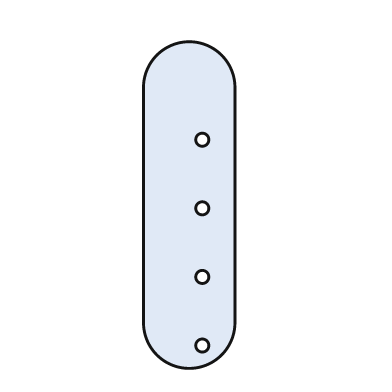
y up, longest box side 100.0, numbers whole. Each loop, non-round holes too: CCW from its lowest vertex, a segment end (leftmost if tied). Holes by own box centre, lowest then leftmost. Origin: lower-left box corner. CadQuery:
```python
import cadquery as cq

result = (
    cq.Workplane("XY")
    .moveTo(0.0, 14.0)
    .threePointArc((14.0, 0.0), (28.0, 14.0))
    .lineTo(28.0, 86.0)
    .threePointArc((14.0, 100.0), (0.0, 86.0))
    .close()
    .moveTo(18.0, 7.0)
    .circle(2.0)
    .moveTo(18.0, 28.0)
    .circle(2.0)
    .moveTo(18.0, 49.0)
    .circle(2.0)
    .moveTo(18.0, 70.0)
    .circle(2.0)
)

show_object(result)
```